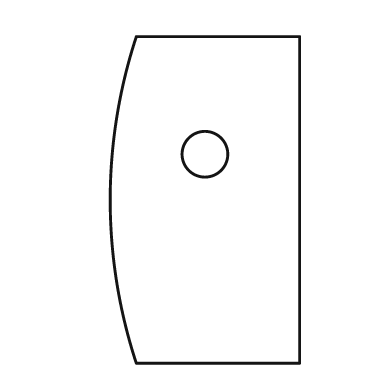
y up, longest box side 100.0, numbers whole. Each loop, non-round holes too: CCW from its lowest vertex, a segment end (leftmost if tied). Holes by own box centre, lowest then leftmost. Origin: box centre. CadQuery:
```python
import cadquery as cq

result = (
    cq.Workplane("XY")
    .moveTo(-21.0, -50.0)
    .lineTo(29.0, -50.0)
    .lineTo(29.0, 50.0)
    .lineTo(-21.0, 50.0)
    .threePointArc((-29.0, 0.0), (-21.0, -50.0))
    .close()
    .moveTo(0.0, 14.0)
    .circle(7.0)
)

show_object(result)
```